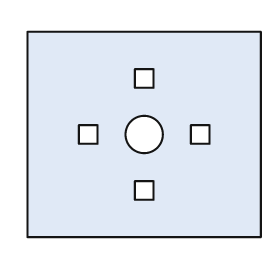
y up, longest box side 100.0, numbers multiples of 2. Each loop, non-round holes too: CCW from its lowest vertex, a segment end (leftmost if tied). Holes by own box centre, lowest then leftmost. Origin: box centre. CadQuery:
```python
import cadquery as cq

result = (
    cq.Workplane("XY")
    .moveTo(-50.0, -44.0)
    .lineTo(50.0, -44.0)
    .lineTo(50.0, 44.0)
    .lineTo(-50.0, 44.0)
    .close()
    .moveTo(-4.0, -28.0)
    .lineTo(4.0, -28.0)
    .lineTo(4.0, -20.0)
    .lineTo(-4.0, -20.0)
    .close()
    .moveTo(-28.0, -4.0)
    .lineTo(-20.0, -4.0)
    .lineTo(-20.0, 4.0)
    .lineTo(-28.0, 4.0)
    .close()
    .moveTo(0.0, 0.0)
    .circle(8.0)
    .moveTo(20.0, -4.0)
    .lineTo(28.0, -4.0)
    .lineTo(28.0, 4.0)
    .lineTo(20.0, 4.0)
    .close()
    .moveTo(-4.0, 20.0)
    .lineTo(4.0, 20.0)
    .lineTo(4.0, 28.0)
    .lineTo(-4.0, 28.0)
    .close()
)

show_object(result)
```